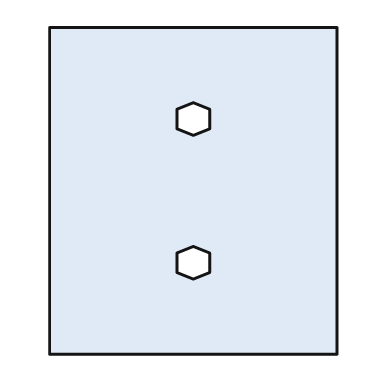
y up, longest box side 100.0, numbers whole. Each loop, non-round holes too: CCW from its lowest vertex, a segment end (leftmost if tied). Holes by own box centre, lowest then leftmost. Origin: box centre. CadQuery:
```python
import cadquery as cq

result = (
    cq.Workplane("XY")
    .moveTo(-44.0, -50.0)
    .lineTo(44.0, -50.0)
    .lineTo(44.0, 50.0)
    .lineTo(-44.0, 50.0)
    .close()
    .moveTo(0.0, -27.0)
    .lineTo(5.0, -25.0)
    .lineTo(5.0, -19.0)
    .lineTo(0.0, -17.0)
    .lineTo(-5.0, -19.0)
    .lineTo(-5.0, -25.0)
    .close()
    .moveTo(0.0, 17.0)
    .lineTo(5.0, 19.0)
    .lineTo(5.0, 25.0)
    .lineTo(0.0, 27.0)
    .lineTo(-5.0, 25.0)
    .lineTo(-5.0, 19.0)
    .close()
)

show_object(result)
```